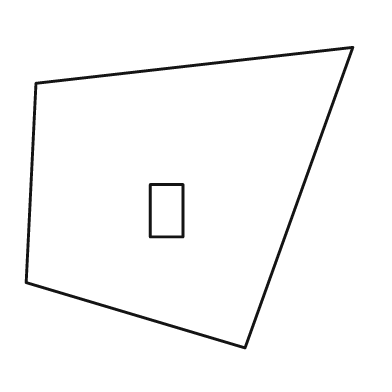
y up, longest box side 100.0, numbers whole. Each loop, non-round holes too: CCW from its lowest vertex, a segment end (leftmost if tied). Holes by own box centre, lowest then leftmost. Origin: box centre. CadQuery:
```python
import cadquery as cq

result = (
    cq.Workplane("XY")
    .moveTo(17.0, -46.0)
    .lineTo(50.0, 46.0)
    .lineTo(-47.0, 35.0)
    .lineTo(-50.0, -26.0)
    .close()
    .moveTo(-12.0, -12.0)
    .lineTo(-2.0, -12.0)
    .lineTo(-2.0, 4.0)
    .lineTo(-12.0, 4.0)
    .close()
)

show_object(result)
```